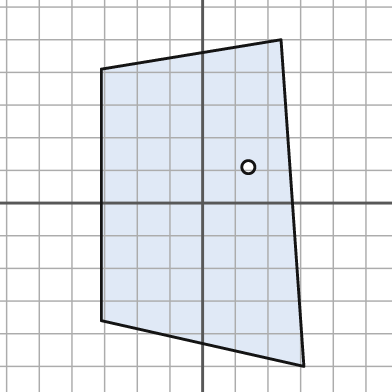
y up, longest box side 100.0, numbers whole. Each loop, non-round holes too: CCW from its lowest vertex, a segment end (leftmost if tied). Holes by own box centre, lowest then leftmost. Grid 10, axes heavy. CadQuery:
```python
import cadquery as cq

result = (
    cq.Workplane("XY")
    .moveTo(31.0, -50.0)
    .lineTo(24.0, 50.0)
    .lineTo(-31.0, 41.0)
    .lineTo(-31.0, -36.0)
    .close()
    .moveTo(14.0, 11.0)
    .circle(2.0)
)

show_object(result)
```